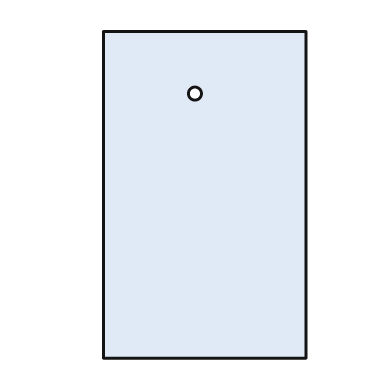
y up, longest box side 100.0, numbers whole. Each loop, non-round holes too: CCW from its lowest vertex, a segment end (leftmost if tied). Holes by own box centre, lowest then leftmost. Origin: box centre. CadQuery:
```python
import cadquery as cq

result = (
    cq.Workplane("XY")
    .moveTo(-31.0, -50.0)
    .lineTo(31.0, -50.0)
    .lineTo(31.0, 50.0)
    .lineTo(-31.0, 50.0)
    .close()
    .moveTo(-3.0, 31.0)
    .circle(2.0)
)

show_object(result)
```